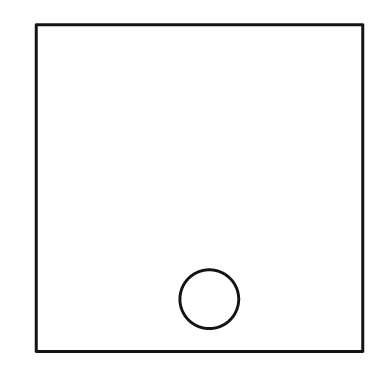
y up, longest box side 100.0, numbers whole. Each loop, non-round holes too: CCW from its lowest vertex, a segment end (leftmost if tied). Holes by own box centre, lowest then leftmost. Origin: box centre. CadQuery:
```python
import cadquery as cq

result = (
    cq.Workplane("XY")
    .moveTo(-50.0, -50.0)
    .lineTo(50.0, -50.0)
    .lineTo(50.0, 50.0)
    .lineTo(-50.0, 50.0)
    .close()
    .moveTo(3.0, -34.0)
    .circle(9.0)
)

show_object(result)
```